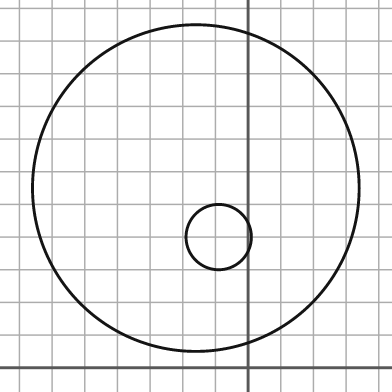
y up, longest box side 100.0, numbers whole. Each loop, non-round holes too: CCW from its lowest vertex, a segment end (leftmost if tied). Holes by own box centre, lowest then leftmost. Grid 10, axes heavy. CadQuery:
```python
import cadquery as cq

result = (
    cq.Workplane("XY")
    .moveTo(-16.0, 55.0)
    .circle(50.0)
    .moveTo(-9.0, 40.0)
    .circle(10.0)
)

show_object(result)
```